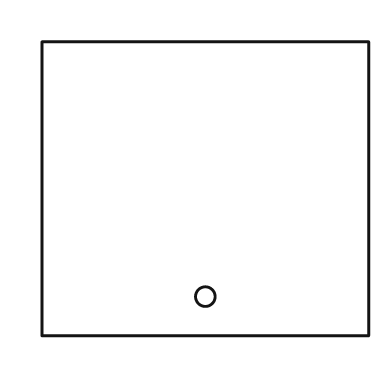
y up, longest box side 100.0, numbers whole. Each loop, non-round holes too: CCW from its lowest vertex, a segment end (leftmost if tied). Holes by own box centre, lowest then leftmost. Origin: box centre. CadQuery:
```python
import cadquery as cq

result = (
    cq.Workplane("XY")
    .moveTo(-50.0, -45.0)
    .lineTo(50.0, -45.0)
    .lineTo(50.0, 45.0)
    .lineTo(-50.0, 45.0)
    .close()
    .moveTo(0.0, -33.0)
    .circle(3.0)
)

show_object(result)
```